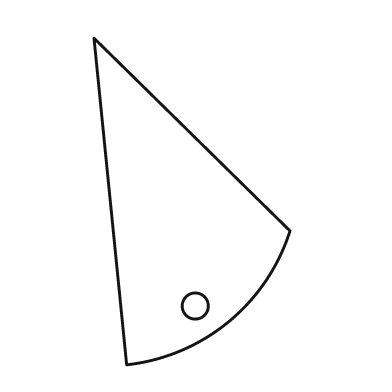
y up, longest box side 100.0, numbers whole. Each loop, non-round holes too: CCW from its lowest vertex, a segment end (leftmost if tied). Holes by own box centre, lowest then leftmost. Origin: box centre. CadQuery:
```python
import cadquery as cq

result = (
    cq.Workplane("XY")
    .moveTo(-20.0, -50.0)
    .threePointArc((11.0, -37.0), (30.0, -9.0))
    .lineTo(-30.0, 50.0)
    .close()
    .moveTo(1.0, -32.0)
    .circle(4.0)
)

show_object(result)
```